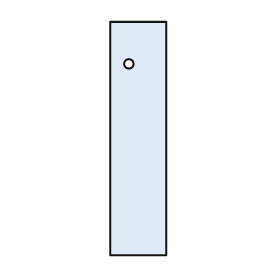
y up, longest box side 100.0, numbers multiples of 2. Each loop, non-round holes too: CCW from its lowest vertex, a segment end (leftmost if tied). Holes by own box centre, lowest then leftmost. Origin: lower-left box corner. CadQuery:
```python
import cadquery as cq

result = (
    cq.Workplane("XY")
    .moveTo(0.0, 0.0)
    .lineTo(24.0, 0.0)
    .lineTo(24.0, 100.0)
    .lineTo(0.0, 100.0)
    .close()
    .moveTo(8.0, 82.0)
    .circle(2.0)
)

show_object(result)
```